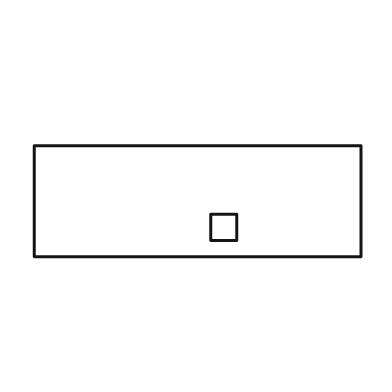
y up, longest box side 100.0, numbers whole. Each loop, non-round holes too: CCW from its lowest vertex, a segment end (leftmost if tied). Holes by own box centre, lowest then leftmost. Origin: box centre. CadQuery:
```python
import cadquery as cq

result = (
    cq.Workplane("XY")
    .moveTo(-50.0, -17.0)
    .lineTo(50.0, -17.0)
    .lineTo(50.0, 17.0)
    .lineTo(-50.0, 17.0)
    .close()
    .moveTo(4.0, -12.0)
    .lineTo(12.0, -12.0)
    .lineTo(12.0, -4.0)
    .lineTo(4.0, -4.0)
    .close()
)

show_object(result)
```